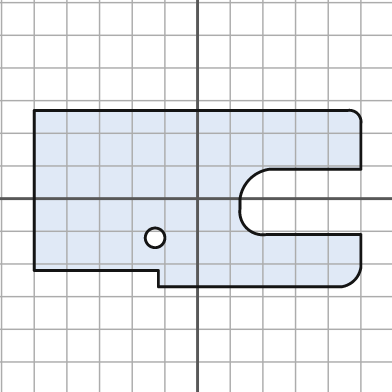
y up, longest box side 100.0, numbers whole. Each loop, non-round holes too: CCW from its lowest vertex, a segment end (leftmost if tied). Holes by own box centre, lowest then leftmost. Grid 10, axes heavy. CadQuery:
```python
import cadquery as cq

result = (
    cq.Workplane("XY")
    .moveTo(-12.0, -27.0)
    .lineTo(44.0, -27.0)
    .threePointArc((48.0, -25.0), (50.0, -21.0))
    .lineTo(50.0, -11.0)
    .lineTo(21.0, -11.0)
    .threePointArc((15.0, -9.0), (13.0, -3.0))
    .lineTo(13.0, 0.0)
    .threePointArc((16.0, 6.0), (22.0, 9.0))
    .lineTo(50.0, 9.0)
    .lineTo(50.0, 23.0)
    .threePointArc((49.0, 26.0), (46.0, 27.0))
    .lineTo(-50.0, 27.0)
    .lineTo(-50.0, -22.0)
    .lineTo(-12.0, -22.0)
    .close()
    .moveTo(-13.0, -12.0)
    .circle(3.0)
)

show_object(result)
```